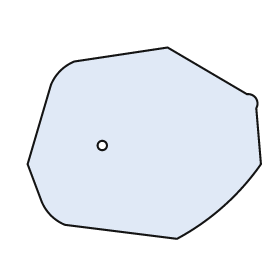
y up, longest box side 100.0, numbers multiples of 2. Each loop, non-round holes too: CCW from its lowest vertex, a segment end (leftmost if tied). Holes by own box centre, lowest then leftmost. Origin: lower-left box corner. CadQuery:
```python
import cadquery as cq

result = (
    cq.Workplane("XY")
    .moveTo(64.0, 0.0)
    .threePointArc((84.0, 14.0), (100.0, 32.0))
    .lineTo(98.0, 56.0)
    .threePointArc((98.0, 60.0), (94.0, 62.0))
    .lineTo(60.0, 82.0)
    .lineTo(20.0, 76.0)
    .threePointArc((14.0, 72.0), (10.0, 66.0))
    .lineTo(0.0, 32.0)
    .lineTo(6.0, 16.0)
    .threePointArc((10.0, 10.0), (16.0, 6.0))
    .close()
    .moveTo(32.0, 40.0)
    .circle(2.0)
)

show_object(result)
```